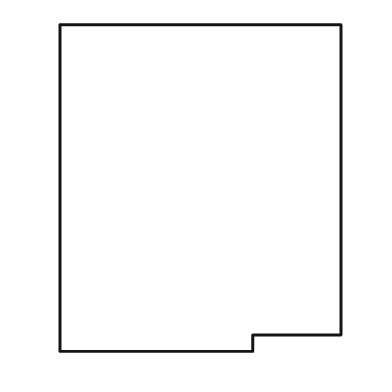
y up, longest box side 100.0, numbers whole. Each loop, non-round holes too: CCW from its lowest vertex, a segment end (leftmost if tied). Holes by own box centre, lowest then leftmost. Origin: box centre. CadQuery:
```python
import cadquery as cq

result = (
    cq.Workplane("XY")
    .moveTo(-43.0, -50.0)
    .lineTo(16.0, -50.0)
    .lineTo(16.0, -45.0)
    .lineTo(43.0, -45.0)
    .lineTo(43.0, 50.0)
    .lineTo(-43.0, 50.0)
    .close()
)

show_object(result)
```